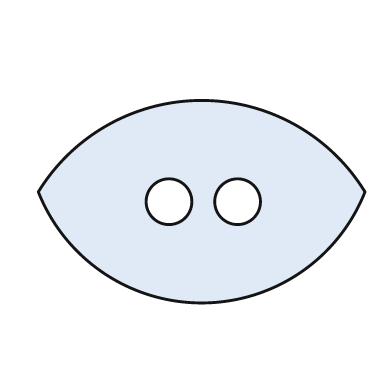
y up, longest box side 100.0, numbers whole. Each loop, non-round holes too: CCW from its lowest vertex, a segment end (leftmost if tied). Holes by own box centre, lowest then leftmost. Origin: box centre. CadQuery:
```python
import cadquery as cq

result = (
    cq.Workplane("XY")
    .moveTo(-50.0, 3.0)
    .threePointArc((0.0, -31.0), (50.0, 3.0))
    .threePointArc((0.0, 31.0), (-50.0, 3.0))
    .close()
    .moveTo(-10.0, 0.0)
    .circle(7.0)
    .moveTo(11.0, 0.0)
    .circle(7.0)
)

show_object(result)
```